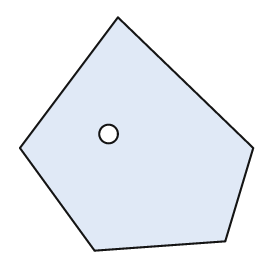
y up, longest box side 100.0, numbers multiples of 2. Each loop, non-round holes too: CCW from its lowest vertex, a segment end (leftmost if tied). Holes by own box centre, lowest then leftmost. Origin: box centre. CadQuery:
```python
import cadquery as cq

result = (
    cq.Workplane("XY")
    .moveTo(-18.0, -50.0)
    .lineTo(38.0, -46.0)
    .lineTo(50.0, -6.0)
    .lineTo(-8.0, 50.0)
    .lineTo(-50.0, -6.0)
    .close()
    .moveTo(-12.0, 0.0)
    .circle(4.0)
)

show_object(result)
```